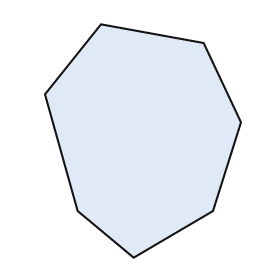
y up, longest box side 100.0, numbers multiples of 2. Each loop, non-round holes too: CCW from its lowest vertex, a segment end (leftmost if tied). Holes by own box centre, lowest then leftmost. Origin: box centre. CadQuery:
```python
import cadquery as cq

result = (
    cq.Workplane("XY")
    .moveTo(-4.0, -50.0)
    .lineTo(30.0, -30.0)
    .lineTo(42.0, 8.0)
    .lineTo(26.0, 42.0)
    .lineTo(-18.0, 50.0)
    .lineTo(-42.0, 20.0)
    .lineTo(-28.0, -30.0)
    .close()
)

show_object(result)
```